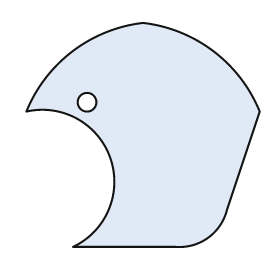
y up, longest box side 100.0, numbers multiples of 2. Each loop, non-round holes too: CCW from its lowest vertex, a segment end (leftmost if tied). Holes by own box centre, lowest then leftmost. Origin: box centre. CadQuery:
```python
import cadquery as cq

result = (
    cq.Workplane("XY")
    .moveTo(-30.0, -48.0)
    .lineTo(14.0, -48.0)
    .threePointArc((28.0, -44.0), (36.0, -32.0))
    .lineTo(50.0, 10.0)
    .threePointArc((30.0, 36.0), (0.0, 48.0))
    .threePointArc((-30.0, 36.0), (-50.0, 10.0))
    .threePointArc((-14.0, -10.0), (-30.0, -48.0))
    .close()
    .moveTo(-24.0, 14.0)
    .circle(4.0)
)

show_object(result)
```